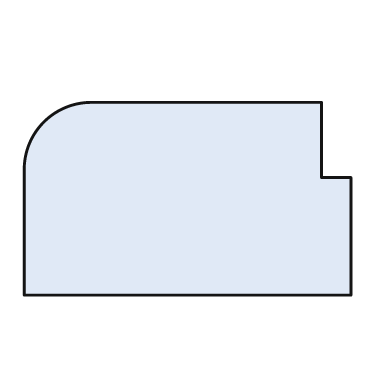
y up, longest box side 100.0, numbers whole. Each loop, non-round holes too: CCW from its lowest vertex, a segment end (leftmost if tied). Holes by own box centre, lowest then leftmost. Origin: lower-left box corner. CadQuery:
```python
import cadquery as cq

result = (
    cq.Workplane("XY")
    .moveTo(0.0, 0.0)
    .lineTo(100.0, 0.0)
    .lineTo(100.0, 36.0)
    .lineTo(91.0, 36.0)
    .lineTo(91.0, 59.0)
    .lineTo(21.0, 59.0)
    .threePointArc((6.0, 53.0), (0.0, 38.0))
    .close()
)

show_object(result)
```